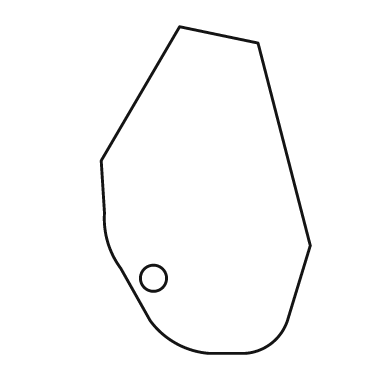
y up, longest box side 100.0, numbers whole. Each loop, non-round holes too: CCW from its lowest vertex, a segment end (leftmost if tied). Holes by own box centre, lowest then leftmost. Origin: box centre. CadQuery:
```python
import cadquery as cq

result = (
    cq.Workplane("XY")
    .moveTo(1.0, -50.0)
    .lineTo(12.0, -50.0)
    .threePointArc((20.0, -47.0), (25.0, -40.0))
    .lineTo(32.0, -17.0)
    .lineTo(16.0, 45.0)
    .lineTo(-8.0, 50.0)
    .lineTo(-32.0, 9.0)
    .lineTo(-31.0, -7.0)
    .threePointArc((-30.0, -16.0), (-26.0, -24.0))
    .lineTo(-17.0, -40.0)
    .threePointArc((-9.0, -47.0), (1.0, -50.0))
    .close()
    .moveTo(-16.0, -27.0)
    .circle(4.0)
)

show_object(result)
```